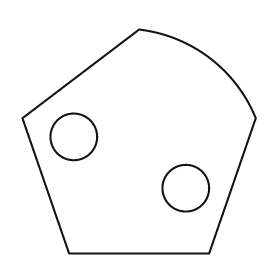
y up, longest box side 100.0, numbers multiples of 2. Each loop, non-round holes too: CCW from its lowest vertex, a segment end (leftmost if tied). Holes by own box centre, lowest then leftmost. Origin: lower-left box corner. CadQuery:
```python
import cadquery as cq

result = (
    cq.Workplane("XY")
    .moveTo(20.0, 0.0)
    .lineTo(80.0, 0.0)
    .lineTo(100.0, 58.0)
    .threePointArc((80.0, 84.0), (50.0, 96.0))
    .lineTo(0.0, 58.0)
    .close()
    .moveTo(70.0, 28.0)
    .circle(10.0)
    .moveTo(22.0, 50.0)
    .circle(10.0)
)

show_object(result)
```